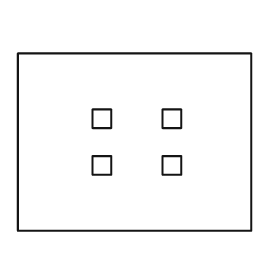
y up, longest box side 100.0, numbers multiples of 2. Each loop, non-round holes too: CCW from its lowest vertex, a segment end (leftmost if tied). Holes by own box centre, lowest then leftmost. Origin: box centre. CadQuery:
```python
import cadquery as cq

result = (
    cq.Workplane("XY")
    .moveTo(-50.0, -38.0)
    .lineTo(50.0, -38.0)
    .lineTo(50.0, 38.0)
    .lineTo(-50.0, 38.0)
    .close()
    .moveTo(-18.0, -14.0)
    .lineTo(-10.0, -14.0)
    .lineTo(-10.0, -6.0)
    .lineTo(-18.0, -6.0)
    .close()
    .moveTo(12.0, -14.0)
    .lineTo(20.0, -14.0)
    .lineTo(20.0, -6.0)
    .lineTo(12.0, -6.0)
    .close()
    .moveTo(-18.0, 6.0)
    .lineTo(-10.0, 6.0)
    .lineTo(-10.0, 14.0)
    .lineTo(-18.0, 14.0)
    .close()
    .moveTo(12.0, 6.0)
    .lineTo(20.0, 6.0)
    .lineTo(20.0, 14.0)
    .lineTo(12.0, 14.0)
    .close()
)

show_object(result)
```